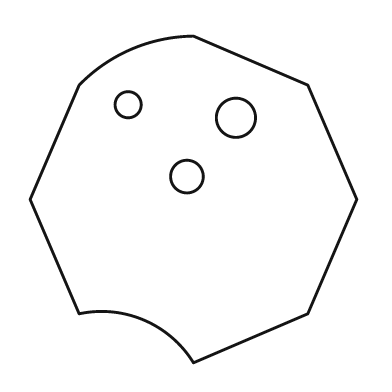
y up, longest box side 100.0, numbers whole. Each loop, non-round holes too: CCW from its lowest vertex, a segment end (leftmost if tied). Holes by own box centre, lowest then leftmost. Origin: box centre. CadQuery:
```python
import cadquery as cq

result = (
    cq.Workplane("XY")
    .moveTo(0.0, -50.0)
    .lineTo(35.0, -35.0)
    .lineTo(50.0, 0.0)
    .lineTo(35.0, 35.0)
    .lineTo(0.0, 50.0)
    .threePointArc((-19.0, 46.0), (-35.0, 35.0))
    .lineTo(-50.0, 0.0)
    .lineTo(-35.0, -35.0)
    .threePointArc((-15.0, -37.0), (0.0, -50.0))
    .close()
    .moveTo(-2.0, 7.0)
    .circle(5.0)
    .moveTo(13.0, 25.0)
    .circle(6.0)
    .moveTo(-20.0, 29.0)
    .circle(4.0)
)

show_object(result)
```